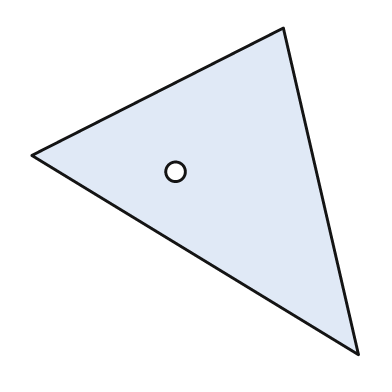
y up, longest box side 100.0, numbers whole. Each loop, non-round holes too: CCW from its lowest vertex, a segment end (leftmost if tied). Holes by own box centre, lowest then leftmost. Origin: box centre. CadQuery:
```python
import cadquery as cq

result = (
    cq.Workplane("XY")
    .moveTo(50.0, -50.0)
    .lineTo(27.0, 50.0)
    .lineTo(-50.0, 11.0)
    .close()
    .moveTo(-6.0, 6.0)
    .circle(3.0)
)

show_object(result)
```